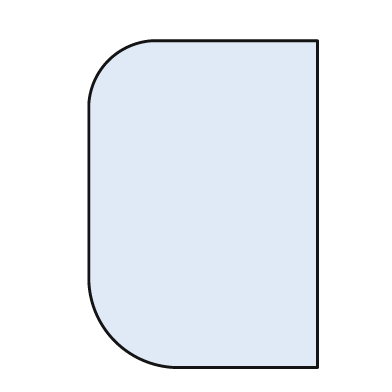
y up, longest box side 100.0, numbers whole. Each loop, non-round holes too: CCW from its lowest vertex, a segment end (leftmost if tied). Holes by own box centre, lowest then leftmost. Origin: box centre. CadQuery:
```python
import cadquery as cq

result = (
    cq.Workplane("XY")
    .moveTo(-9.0, -50.0)
    .lineTo(35.0, -50.0)
    .lineTo(35.0, 50.0)
    .lineTo(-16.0, 50.0)
    .threePointArc((-29.0, 44.0), (-35.0, 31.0))
    .lineTo(-35.0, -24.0)
    .threePointArc((-27.0, -42.0), (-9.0, -50.0))
    .close()
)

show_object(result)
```